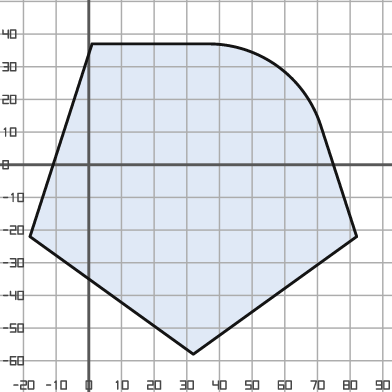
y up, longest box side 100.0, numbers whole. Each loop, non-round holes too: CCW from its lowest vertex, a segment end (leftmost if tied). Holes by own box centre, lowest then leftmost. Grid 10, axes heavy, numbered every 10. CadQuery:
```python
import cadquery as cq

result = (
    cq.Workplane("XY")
    .moveTo(32.0, -58.0)
    .lineTo(82.0, -22.0)
    .lineTo(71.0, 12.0)
    .threePointArc((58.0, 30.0), (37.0, 37.0))
    .lineTo(1.0, 37.0)
    .lineTo(-18.0, -22.0)
    .close()
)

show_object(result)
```